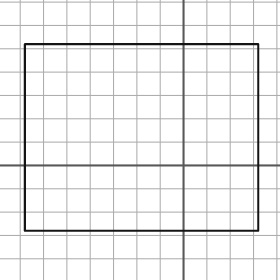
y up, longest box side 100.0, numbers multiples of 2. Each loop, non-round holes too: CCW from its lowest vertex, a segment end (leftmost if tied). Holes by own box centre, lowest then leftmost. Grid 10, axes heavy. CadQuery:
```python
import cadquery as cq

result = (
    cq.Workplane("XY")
    .moveTo(-68.0, -28.0)
    .lineTo(32.0, -28.0)
    .lineTo(32.0, 52.0)
    .lineTo(-68.0, 52.0)
    .close()
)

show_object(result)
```